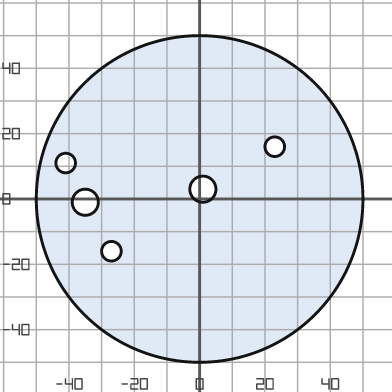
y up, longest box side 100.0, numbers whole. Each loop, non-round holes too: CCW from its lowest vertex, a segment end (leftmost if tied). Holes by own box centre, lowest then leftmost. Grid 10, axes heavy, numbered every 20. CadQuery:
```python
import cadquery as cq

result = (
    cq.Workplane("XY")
    .moveTo(0.0, 0.0)
    .circle(50.0)
    .moveTo(-27.0, -16.0)
    .circle(3.0)
    .moveTo(-35.0, -1.0)
    .circle(4.0)
    .moveTo(1.0, 3.0)
    .circle(4.0)
    .moveTo(-41.0, 11.0)
    .circle(3.0)
    .moveTo(23.0, 16.0)
    .circle(3.0)
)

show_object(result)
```